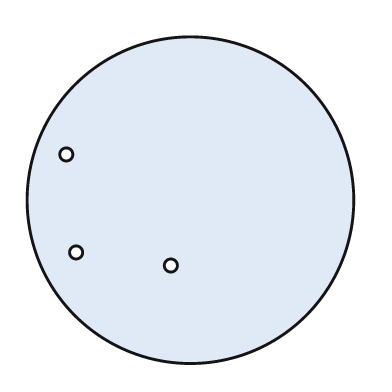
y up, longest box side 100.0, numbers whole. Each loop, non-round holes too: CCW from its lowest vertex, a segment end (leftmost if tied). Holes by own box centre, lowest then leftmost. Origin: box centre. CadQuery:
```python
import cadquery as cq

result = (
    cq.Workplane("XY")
    .moveTo(0.0, 0.0)
    .circle(50.0)
    .moveTo(-6.0, -20.0)
    .circle(2.0)
    .moveTo(-35.0, -16.0)
    .circle(2.0)
    .moveTo(-38.0, 14.0)
    .circle(2.0)
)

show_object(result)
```